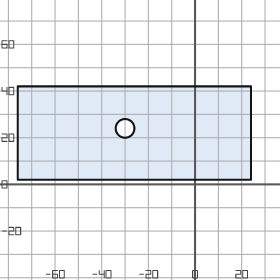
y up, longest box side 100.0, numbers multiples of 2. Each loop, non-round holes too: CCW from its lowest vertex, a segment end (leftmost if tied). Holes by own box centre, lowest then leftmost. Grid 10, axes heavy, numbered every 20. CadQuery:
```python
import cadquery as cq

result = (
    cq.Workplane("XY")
    .moveTo(-76.0, 2.0)
    .lineTo(24.0, 2.0)
    .lineTo(24.0, 42.0)
    .lineTo(-76.0, 42.0)
    .close()
    .moveTo(-30.0, 24.0)
    .circle(4.0)
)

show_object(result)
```